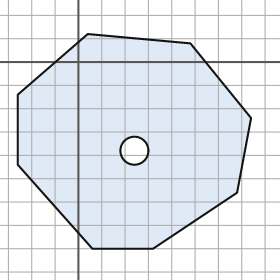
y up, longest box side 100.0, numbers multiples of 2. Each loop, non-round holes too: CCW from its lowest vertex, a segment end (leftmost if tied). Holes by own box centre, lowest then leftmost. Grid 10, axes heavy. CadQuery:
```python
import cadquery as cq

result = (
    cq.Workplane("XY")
    .moveTo(6.0, -80.0)
    .lineTo(32.0, -80.0)
    .lineTo(68.0, -56.0)
    .lineTo(74.0, -24.0)
    .lineTo(48.0, 8.0)
    .lineTo(4.0, 12.0)
    .lineTo(-26.0, -14.0)
    .lineTo(-26.0, -44.0)
    .close()
    .moveTo(24.0, -38.0)
    .circle(6.0)
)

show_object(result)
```